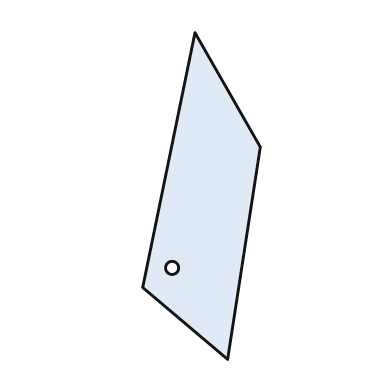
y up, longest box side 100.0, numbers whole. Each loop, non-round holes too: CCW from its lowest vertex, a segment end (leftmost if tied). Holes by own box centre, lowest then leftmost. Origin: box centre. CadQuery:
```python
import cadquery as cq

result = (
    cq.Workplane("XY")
    .moveTo(8.0, -50.0)
    .lineTo(18.0, 15.0)
    .lineTo(-2.0, 50.0)
    .lineTo(-18.0, -28.0)
    .close()
    .moveTo(-9.0, -22.0)
    .circle(2.0)
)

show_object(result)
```